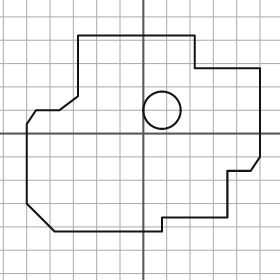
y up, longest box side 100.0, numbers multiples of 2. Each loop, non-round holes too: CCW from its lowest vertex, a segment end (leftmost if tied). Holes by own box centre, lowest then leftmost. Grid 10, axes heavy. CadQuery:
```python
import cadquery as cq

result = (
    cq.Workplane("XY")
    .moveTo(-38.0, -42.0)
    .lineTo(8.0, -42.0)
    .lineTo(8.0, -36.0)
    .lineTo(36.0, -36.0)
    .lineTo(36.0, -16.0)
    .lineTo(46.0, -16.0)
    .lineTo(50.0, -10.0)
    .lineTo(50.0, 28.0)
    .lineTo(22.0, 28.0)
    .lineTo(22.0, 42.0)
    .lineTo(-28.0, 42.0)
    .lineTo(-28.0, 16.0)
    .lineTo(-36.0, 10.0)
    .lineTo(-46.0, 10.0)
    .lineTo(-50.0, 4.0)
    .lineTo(-50.0, -30.0)
    .close()
    .moveTo(8.0, 10.0)
    .circle(8.0)
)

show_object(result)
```